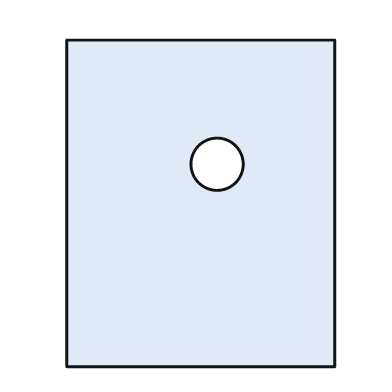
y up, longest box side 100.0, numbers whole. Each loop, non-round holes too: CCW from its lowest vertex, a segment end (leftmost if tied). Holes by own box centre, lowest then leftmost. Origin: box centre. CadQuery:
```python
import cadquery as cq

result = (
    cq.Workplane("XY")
    .moveTo(-41.0, -50.0)
    .lineTo(41.0, -50.0)
    .lineTo(41.0, 50.0)
    .lineTo(-41.0, 50.0)
    .close()
    .moveTo(5.0, 12.0)
    .circle(8.0)
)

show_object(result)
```